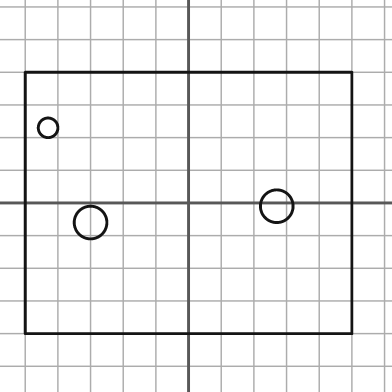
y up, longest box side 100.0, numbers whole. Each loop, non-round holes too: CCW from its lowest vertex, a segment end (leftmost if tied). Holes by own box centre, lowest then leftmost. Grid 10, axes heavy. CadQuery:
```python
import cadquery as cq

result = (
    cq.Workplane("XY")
    .moveTo(-50.0, -40.0)
    .lineTo(50.0, -40.0)
    .lineTo(50.0, 40.0)
    .lineTo(-50.0, 40.0)
    .close()
    .moveTo(-30.0, -6.0)
    .circle(5.0)
    .moveTo(27.0, -1.0)
    .circle(5.0)
    .moveTo(-43.0, 23.0)
    .circle(3.0)
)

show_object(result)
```